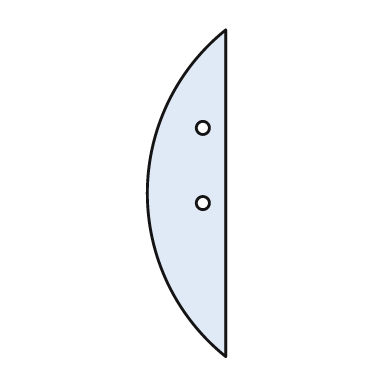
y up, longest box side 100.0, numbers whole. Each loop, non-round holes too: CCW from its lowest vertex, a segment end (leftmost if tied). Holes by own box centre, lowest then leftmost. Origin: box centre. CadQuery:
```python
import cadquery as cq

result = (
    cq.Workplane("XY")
    .moveTo(12.0, -50.0)
    .lineTo(12.0, 50.0)
    .threePointArc((-12.0, 0.0), (12.0, -50.0))
    .close()
    .moveTo(5.0, -3.0)
    .circle(2.0)
    .moveTo(5.0, 20.0)
    .circle(2.0)
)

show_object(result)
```